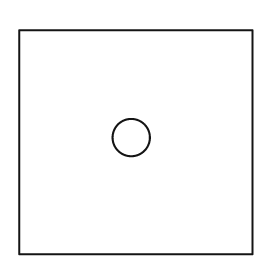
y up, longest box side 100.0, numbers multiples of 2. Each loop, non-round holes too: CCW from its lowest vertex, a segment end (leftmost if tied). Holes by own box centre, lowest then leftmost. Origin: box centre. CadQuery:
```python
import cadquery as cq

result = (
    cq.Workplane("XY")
    .moveTo(-50.0, -48.0)
    .lineTo(50.0, -48.0)
    .lineTo(50.0, 48.0)
    .lineTo(-50.0, 48.0)
    .close()
    .moveTo(-2.0, 2.0)
    .circle(8.0)
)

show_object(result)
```